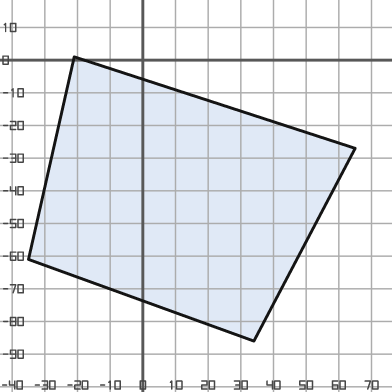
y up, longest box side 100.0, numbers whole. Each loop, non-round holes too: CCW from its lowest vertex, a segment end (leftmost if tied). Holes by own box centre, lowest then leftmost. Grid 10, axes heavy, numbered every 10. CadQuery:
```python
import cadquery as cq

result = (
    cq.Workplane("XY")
    .moveTo(34.0, -86.0)
    .lineTo(65.0, -27.0)
    .lineTo(-21.0, 1.0)
    .lineTo(-35.0, -61.0)
    .close()
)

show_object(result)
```